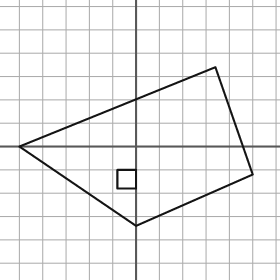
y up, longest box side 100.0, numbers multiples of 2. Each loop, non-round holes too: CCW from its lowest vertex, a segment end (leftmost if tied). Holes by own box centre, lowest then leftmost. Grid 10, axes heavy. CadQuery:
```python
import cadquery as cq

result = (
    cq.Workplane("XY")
    .moveTo(0.0, -34.0)
    .lineTo(50.0, -12.0)
    .lineTo(34.0, 34.0)
    .lineTo(-50.0, 0.0)
    .close()
    .moveTo(-8.0, -18.0)
    .lineTo(0.0, -18.0)
    .lineTo(0.0, -10.0)
    .lineTo(-8.0, -10.0)
    .close()
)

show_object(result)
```